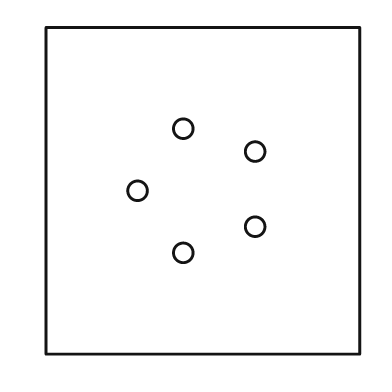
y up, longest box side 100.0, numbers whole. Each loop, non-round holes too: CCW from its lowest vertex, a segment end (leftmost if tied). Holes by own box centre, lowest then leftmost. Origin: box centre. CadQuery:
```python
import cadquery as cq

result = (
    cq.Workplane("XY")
    .moveTo(-48.0, -50.0)
    .lineTo(48.0, -50.0)
    .lineTo(48.0, 50.0)
    .lineTo(-48.0, 50.0)
    .close()
    .moveTo(-6.0, -19.0)
    .circle(3.0)
    .moveTo(16.0, -11.0)
    .circle(3.0)
    .moveTo(-20.0, 0.0)
    .circle(3.0)
    .moveTo(16.0, 12.0)
    .circle(3.0)
    .moveTo(-6.0, 19.0)
    .circle(3.0)
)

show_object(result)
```